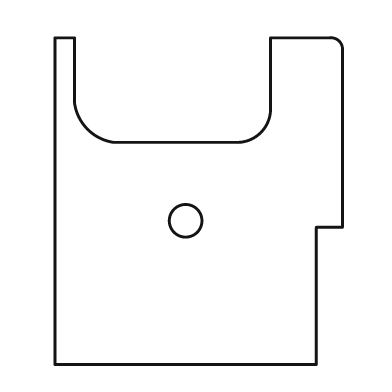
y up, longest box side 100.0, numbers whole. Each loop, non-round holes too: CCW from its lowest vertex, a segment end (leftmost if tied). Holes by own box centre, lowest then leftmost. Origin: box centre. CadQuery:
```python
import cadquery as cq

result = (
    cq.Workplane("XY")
    .moveTo(-44.0, -50.0)
    .lineTo(36.0, -50.0)
    .lineTo(36.0, -8.0)
    .lineTo(44.0, -8.0)
    .lineTo(44.0, 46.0)
    .threePointArc((43.0, 49.0), (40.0, 50.0))
    .lineTo(22.0, 50.0)
    .lineTo(22.0, 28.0)
    .threePointArc((19.0, 21.0), (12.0, 18.0))
    .lineTo(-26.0, 18.0)
    .threePointArc((-34.0, 22.0), (-38.0, 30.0))
    .lineTo(-38.0, 50.0)
    .lineTo(-44.0, 50.0)
    .close()
    .moveTo(-4.0, -6.0)
    .circle(5.0)
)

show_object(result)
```